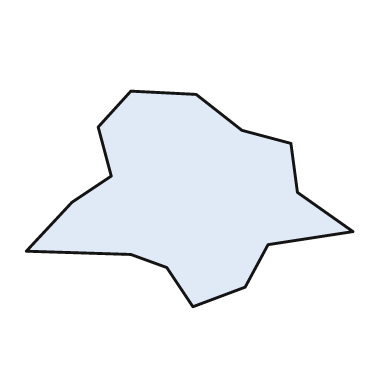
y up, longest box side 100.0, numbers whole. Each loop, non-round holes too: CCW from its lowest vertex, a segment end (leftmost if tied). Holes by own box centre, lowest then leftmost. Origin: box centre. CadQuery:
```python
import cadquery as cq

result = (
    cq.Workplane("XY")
    .moveTo(1.0, -33.0)
    .lineTo(17.0, -27.0)
    .lineTo(24.0, -14.0)
    .lineTo(50.0, -10.0)
    .lineTo(33.0, 2.0)
    .lineTo(31.0, 17.0)
    .lineTo(16.0, 21.0)
    .lineTo(2.0, 32.0)
    .lineTo(-18.0, 33.0)
    .lineTo(-28.0, 22.0)
    .lineTo(-24.0, 7.0)
    .lineTo(-36.0, -1.0)
    .lineTo(-50.0, -16.0)
    .lineTo(-18.0, -17.0)
    .lineTo(-7.0, -21.0)
    .close()
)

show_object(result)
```